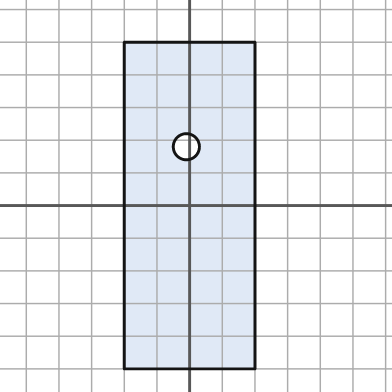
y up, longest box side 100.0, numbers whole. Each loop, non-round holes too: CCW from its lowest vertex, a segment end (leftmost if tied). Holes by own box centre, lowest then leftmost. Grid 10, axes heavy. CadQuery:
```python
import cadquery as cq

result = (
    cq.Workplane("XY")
    .moveTo(-20.0, -50.0)
    .lineTo(20.0, -50.0)
    .lineTo(20.0, 50.0)
    .lineTo(-20.0, 50.0)
    .close()
    .moveTo(-1.0, 18.0)
    .circle(4.0)
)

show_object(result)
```